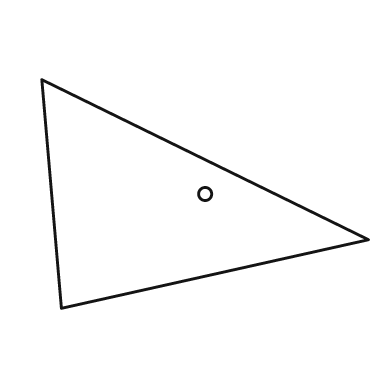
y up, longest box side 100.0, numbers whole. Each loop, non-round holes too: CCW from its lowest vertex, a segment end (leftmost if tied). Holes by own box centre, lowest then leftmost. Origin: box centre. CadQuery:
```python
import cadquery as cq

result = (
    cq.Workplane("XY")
    .moveTo(-44.0, -35.0)
    .lineTo(50.0, -14.0)
    .lineTo(-50.0, 35.0)
    .close()
    .moveTo(0.0, 0.0)
    .circle(2.0)
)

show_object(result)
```